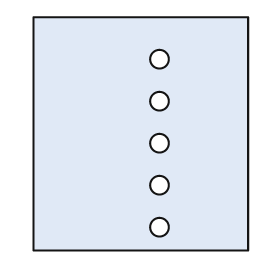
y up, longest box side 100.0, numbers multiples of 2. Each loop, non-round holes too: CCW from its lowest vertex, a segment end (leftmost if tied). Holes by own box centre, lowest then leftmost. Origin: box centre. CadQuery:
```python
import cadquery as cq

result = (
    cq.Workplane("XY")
    .moveTo(-46.0, -50.0)
    .lineTo(46.0, -50.0)
    .lineTo(46.0, 50.0)
    .lineTo(-46.0, 50.0)
    .close()
    .moveTo(8.0, -40.0)
    .circle(4.0)
    .moveTo(8.0, -22.0)
    .circle(4.0)
    .moveTo(8.0, -4.0)
    .circle(4.0)
    .moveTo(8.0, 14.0)
    .circle(4.0)
    .moveTo(8.0, 32.0)
    .circle(4.0)
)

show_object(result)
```